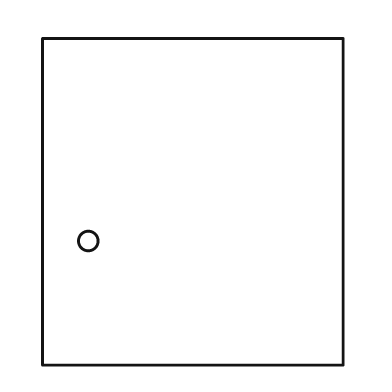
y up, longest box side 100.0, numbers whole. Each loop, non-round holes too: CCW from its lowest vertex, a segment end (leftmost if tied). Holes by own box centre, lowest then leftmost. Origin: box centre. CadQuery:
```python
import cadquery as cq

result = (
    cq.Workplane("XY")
    .moveTo(-46.0, -50.0)
    .lineTo(46.0, -50.0)
    .lineTo(46.0, 50.0)
    .lineTo(-46.0, 50.0)
    .close()
    .moveTo(-32.0, -12.0)
    .circle(3.0)
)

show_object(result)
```